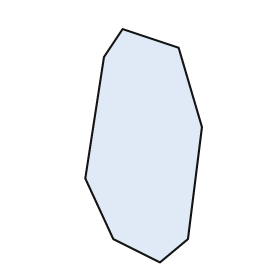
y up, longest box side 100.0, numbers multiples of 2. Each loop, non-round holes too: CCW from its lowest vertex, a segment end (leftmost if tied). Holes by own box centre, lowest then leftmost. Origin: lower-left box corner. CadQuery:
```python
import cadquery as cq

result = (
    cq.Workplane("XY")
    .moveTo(32.0, 0.0)
    .lineTo(44.0, 10.0)
    .lineTo(50.0, 58.0)
    .lineTo(40.0, 92.0)
    .lineTo(16.0, 100.0)
    .lineTo(8.0, 88.0)
    .lineTo(0.0, 36.0)
    .lineTo(12.0, 10.0)
    .close()
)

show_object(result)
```